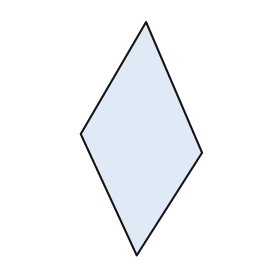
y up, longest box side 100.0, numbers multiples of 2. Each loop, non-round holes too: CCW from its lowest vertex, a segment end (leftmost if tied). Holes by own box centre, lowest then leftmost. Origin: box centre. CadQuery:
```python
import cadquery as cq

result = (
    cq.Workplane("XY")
    .moveTo(-2.0, -50.0)
    .lineTo(26.0, -6.0)
    .lineTo(2.0, 50.0)
    .lineTo(-26.0, 2.0)
    .close()
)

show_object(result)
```